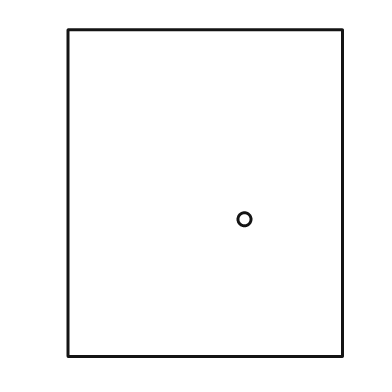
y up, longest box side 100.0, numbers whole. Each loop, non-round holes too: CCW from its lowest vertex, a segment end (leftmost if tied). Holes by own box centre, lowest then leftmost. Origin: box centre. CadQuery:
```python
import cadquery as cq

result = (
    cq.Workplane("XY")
    .moveTo(-42.0, -50.0)
    .lineTo(42.0, -50.0)
    .lineTo(42.0, 50.0)
    .lineTo(-42.0, 50.0)
    .close()
    .moveTo(12.0, -8.0)
    .circle(2.0)
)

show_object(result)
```